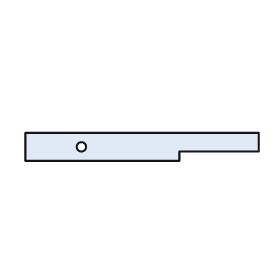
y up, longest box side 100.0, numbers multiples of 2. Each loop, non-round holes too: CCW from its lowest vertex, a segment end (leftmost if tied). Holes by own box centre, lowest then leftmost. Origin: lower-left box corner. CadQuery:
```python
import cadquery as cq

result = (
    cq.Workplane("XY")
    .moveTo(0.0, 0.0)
    .lineTo(66.0, 0.0)
    .lineTo(66.0, 4.0)
    .lineTo(100.0, 4.0)
    .lineTo(100.0, 12.0)
    .lineTo(0.0, 12.0)
    .close()
    .moveTo(24.0, 6.0)
    .circle(2.0)
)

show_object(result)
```